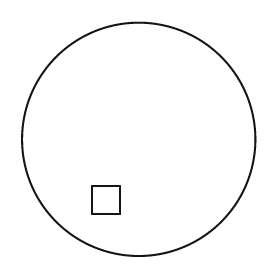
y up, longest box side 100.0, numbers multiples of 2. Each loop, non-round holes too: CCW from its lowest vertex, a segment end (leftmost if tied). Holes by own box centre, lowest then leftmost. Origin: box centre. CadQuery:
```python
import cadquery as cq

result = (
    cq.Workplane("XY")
    .moveTo(0.0, 0.0)
    .circle(50.0)
    .moveTo(-20.0, -32.0)
    .lineTo(-8.0, -32.0)
    .lineTo(-8.0, -20.0)
    .lineTo(-20.0, -20.0)
    .close()
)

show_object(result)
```